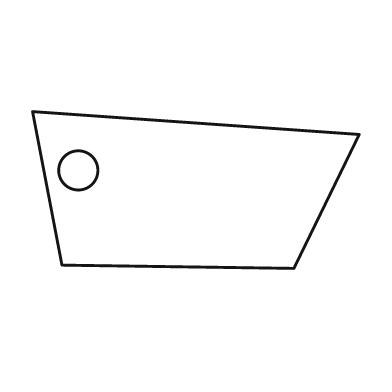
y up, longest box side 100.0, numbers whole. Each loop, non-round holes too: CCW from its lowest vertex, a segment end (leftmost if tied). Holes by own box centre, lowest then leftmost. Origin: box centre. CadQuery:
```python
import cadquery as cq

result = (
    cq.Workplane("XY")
    .moveTo(30.0, -24.0)
    .lineTo(50.0, 17.0)
    .lineTo(-50.0, 24.0)
    .lineTo(-41.0, -23.0)
    .close()
    .moveTo(-36.0, 6.0)
    .circle(6.0)
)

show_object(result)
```